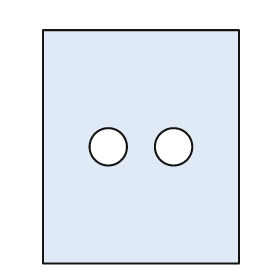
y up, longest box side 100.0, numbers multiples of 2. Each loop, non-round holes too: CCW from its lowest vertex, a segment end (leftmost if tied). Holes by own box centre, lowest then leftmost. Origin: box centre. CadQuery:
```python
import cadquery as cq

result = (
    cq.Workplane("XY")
    .moveTo(-42.0, -50.0)
    .lineTo(42.0, -50.0)
    .lineTo(42.0, 50.0)
    .lineTo(-42.0, 50.0)
    .close()
    .moveTo(-14.0, 0.0)
    .circle(8.0)
    .moveTo(14.0, 0.0)
    .circle(8.0)
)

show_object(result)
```